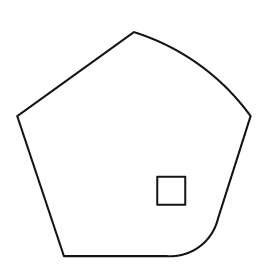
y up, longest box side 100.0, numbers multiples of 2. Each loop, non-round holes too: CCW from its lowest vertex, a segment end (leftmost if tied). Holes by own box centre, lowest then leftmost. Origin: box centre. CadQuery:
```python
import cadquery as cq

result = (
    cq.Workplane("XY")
    .moveTo(-30.0, -48.0)
    .lineTo(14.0, -48.0)
    .threePointArc((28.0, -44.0), (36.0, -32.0))
    .lineTo(50.0, 12.0)
    .threePointArc((28.0, 34.0), (0.0, 48.0))
    .lineTo(-50.0, 12.0)
    .close()
    .moveTo(10.0, -26.0)
    .lineTo(22.0, -26.0)
    .lineTo(22.0, -14.0)
    .lineTo(10.0, -14.0)
    .close()
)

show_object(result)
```